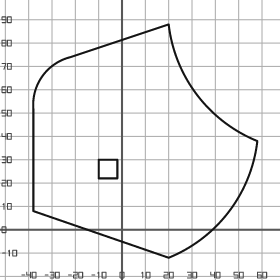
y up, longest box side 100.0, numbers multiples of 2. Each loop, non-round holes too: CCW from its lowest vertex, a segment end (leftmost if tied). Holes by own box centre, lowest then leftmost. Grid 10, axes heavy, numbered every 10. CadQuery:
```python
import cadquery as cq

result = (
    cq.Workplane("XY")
    .moveTo(20.0, -12.0)
    .threePointArc((46.0, 8.0), (58.0, 38.0))
    .threePointArc((32.0, 58.0), (20.0, 88.0))
    .lineTo(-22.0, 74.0)
    .threePointArc((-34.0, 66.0), (-38.0, 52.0))
    .lineTo(-38.0, 8.0)
    .close()
    .moveTo(-10.0, 22.0)
    .lineTo(-2.0, 22.0)
    .lineTo(-2.0, 30.0)
    .lineTo(-10.0, 30.0)
    .close()
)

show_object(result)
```